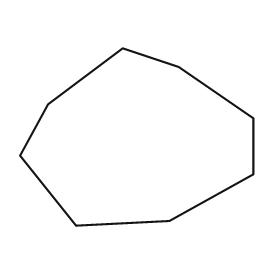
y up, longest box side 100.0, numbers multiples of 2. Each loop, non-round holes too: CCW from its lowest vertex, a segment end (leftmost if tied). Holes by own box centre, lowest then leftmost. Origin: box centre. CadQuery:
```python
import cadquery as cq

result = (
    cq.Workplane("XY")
    .moveTo(-26.0, -38.0)
    .lineTo(14.0, -36.0)
    .lineTo(50.0, -16.0)
    .lineTo(50.0, 8.0)
    .lineTo(18.0, 30.0)
    .lineTo(-6.0, 38.0)
    .lineTo(-38.0, 14.0)
    .lineTo(-50.0, -8.0)
    .close()
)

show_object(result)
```